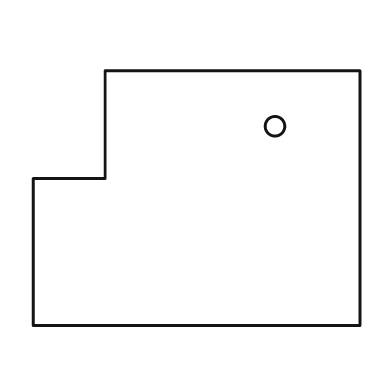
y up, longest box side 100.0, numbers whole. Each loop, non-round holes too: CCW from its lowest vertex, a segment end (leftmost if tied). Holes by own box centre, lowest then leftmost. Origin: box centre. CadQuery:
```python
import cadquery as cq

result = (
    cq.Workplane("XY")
    .moveTo(-50.0, -39.0)
    .lineTo(50.0, -39.0)
    .lineTo(50.0, 39.0)
    .lineTo(-28.0, 39.0)
    .lineTo(-28.0, 6.0)
    .lineTo(-50.0, 6.0)
    .close()
    .moveTo(24.0, 22.0)
    .circle(3.0)
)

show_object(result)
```